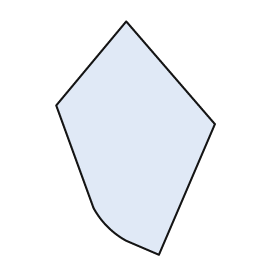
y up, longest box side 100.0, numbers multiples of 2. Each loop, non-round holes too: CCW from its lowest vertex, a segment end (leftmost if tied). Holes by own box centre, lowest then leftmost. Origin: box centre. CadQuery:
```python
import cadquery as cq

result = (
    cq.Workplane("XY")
    .moveTo(10.0, -50.0)
    .lineTo(34.0, 6.0)
    .lineTo(-4.0, 50.0)
    .lineTo(-34.0, 14.0)
    .lineTo(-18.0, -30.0)
    .threePointArc((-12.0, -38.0), (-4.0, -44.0))
    .close()
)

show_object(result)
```